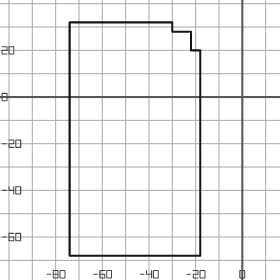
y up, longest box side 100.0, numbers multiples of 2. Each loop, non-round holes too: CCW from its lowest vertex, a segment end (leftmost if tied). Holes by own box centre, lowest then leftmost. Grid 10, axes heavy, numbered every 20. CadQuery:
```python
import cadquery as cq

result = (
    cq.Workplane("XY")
    .moveTo(-74.0, -68.0)
    .lineTo(-18.0, -68.0)
    .lineTo(-18.0, 20.0)
    .lineTo(-22.0, 20.0)
    .lineTo(-22.0, 28.0)
    .lineTo(-30.0, 28.0)
    .lineTo(-30.0, 32.0)
    .lineTo(-74.0, 32.0)
    .close()
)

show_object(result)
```